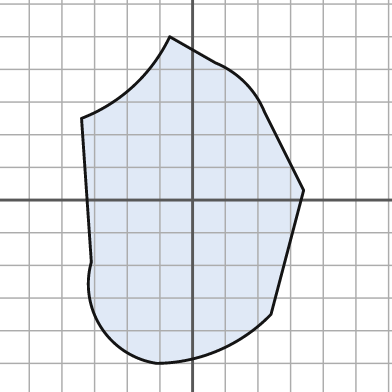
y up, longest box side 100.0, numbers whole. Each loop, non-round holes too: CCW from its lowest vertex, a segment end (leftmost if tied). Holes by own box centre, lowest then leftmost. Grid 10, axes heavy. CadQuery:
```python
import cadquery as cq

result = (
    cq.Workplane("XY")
    .moveTo(-11.0, -50.0)
    .threePointArc((8.0, -46.0), (24.0, -35.0))
    .lineTo(34.0, 3.0)
    .lineTo(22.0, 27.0)
    .threePointArc((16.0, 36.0), (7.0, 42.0))
    .lineTo(-7.0, 50.0)
    .threePointArc((-18.0, 35.0), (-34.0, 25.0))
    .lineTo(-31.0, -19.0)
    .threePointArc((-28.0, -39.0), (-11.0, -50.0))
    .close()
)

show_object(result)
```